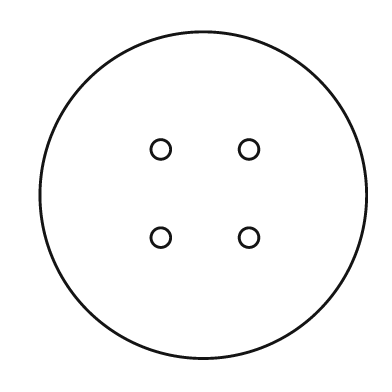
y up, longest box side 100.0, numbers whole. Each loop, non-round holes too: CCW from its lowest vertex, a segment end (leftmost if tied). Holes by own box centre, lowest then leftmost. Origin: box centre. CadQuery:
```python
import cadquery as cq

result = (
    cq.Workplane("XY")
    .moveTo(0.0, 0.0)
    .circle(50.0)
    .moveTo(-13.0, -13.0)
    .circle(3.0)
    .moveTo(14.0, -13.0)
    .circle(3.0)
    .moveTo(-13.0, 14.0)
    .circle(3.0)
    .moveTo(14.0, 14.0)
    .circle(3.0)
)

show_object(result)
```